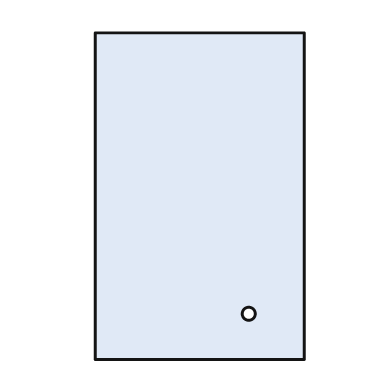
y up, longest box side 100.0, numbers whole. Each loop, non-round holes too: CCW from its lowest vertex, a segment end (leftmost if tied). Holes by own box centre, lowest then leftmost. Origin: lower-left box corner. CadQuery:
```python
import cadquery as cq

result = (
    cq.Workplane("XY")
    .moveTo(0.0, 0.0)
    .lineTo(64.0, 0.0)
    .lineTo(64.0, 100.0)
    .lineTo(0.0, 100.0)
    .close()
    .moveTo(47.0, 14.0)
    .circle(2.0)
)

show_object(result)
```